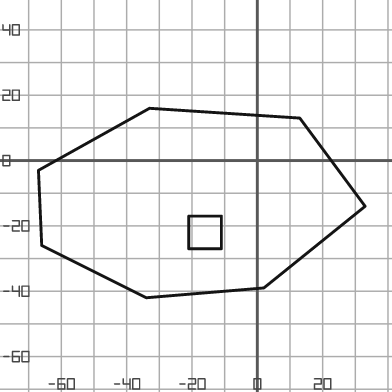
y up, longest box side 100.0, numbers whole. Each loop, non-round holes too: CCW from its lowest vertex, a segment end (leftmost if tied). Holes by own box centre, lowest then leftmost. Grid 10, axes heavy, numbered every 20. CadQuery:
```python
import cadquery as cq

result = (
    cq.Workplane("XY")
    .moveTo(-34.0, -42.0)
    .lineTo(2.0, -39.0)
    .lineTo(33.0, -14.0)
    .lineTo(13.0, 13.0)
    .lineTo(-33.0, 16.0)
    .lineTo(-67.0, -3.0)
    .lineTo(-66.0, -26.0)
    .close()
    .moveTo(-21.0, -27.0)
    .lineTo(-11.0, -27.0)
    .lineTo(-11.0, -17.0)
    .lineTo(-21.0, -17.0)
    .close()
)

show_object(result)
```